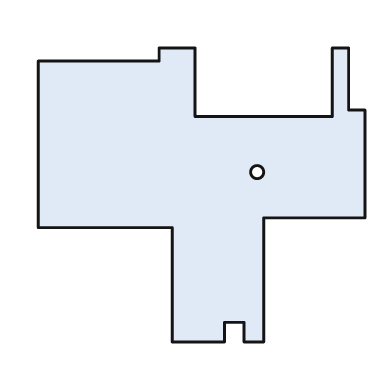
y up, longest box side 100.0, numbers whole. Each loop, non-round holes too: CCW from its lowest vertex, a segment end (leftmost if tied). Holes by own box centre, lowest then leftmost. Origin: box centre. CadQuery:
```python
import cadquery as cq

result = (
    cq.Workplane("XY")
    .moveTo(-9.0, -45.0)
    .lineTo(7.0, -45.0)
    .lineTo(7.0, -39.0)
    .lineTo(13.0, -39.0)
    .lineTo(13.0, -45.0)
    .lineTo(19.0, -45.0)
    .lineTo(19.0, -7.0)
    .lineTo(50.0, -7.0)
    .lineTo(50.0, 26.0)
    .lineTo(45.0, 26.0)
    .lineTo(45.0, 45.0)
    .lineTo(40.0, 45.0)
    .lineTo(40.0, 24.0)
    .lineTo(-2.0, 24.0)
    .lineTo(-2.0, 45.0)
    .lineTo(-13.0, 45.0)
    .lineTo(-13.0, 41.0)
    .lineTo(-50.0, 41.0)
    .lineTo(-50.0, -10.0)
    .lineTo(-9.0, -10.0)
    .close()
    .moveTo(17.0, 7.0)
    .circle(2.0)
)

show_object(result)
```